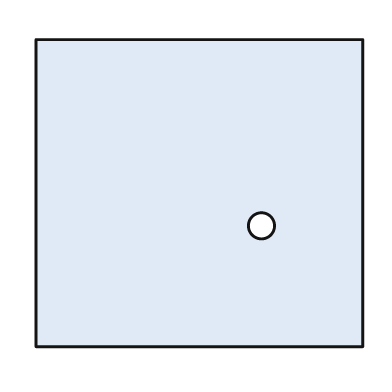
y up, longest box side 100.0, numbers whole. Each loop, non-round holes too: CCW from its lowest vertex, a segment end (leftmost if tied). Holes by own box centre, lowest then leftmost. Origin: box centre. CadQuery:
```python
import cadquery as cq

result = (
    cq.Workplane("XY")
    .moveTo(-50.0, -47.0)
    .lineTo(50.0, -47.0)
    .lineTo(50.0, 47.0)
    .lineTo(-50.0, 47.0)
    .close()
    .moveTo(19.0, -10.0)
    .circle(4.0)
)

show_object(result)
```